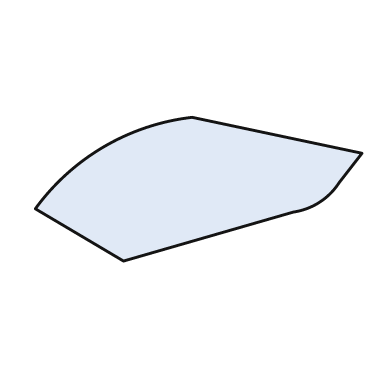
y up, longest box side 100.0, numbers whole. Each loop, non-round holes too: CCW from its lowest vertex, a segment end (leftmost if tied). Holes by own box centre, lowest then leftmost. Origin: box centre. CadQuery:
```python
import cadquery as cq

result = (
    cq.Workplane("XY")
    .moveTo(-23.0, -22.0)
    .lineTo(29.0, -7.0)
    .threePointArc((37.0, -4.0), (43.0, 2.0))
    .lineTo(50.0, 11.0)
    .lineTo(-2.0, 22.0)
    .threePointArc((-29.0, 13.0), (-50.0, -6.0))
    .close()
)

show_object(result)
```